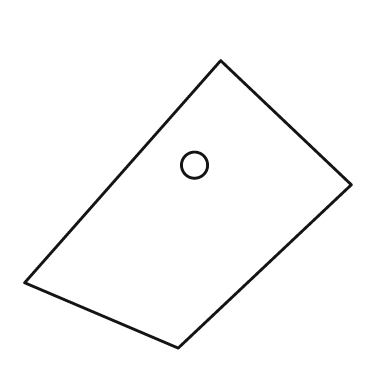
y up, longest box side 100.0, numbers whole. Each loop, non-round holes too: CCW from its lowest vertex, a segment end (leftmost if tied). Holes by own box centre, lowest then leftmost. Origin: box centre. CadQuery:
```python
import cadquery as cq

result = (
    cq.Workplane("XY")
    .moveTo(-3.0, -44.0)
    .lineTo(50.0, 6.0)
    .lineTo(10.0, 44.0)
    .lineTo(-50.0, -24.0)
    .close()
    .moveTo(2.0, 12.0)
    .circle(4.0)
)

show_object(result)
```